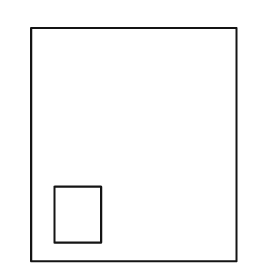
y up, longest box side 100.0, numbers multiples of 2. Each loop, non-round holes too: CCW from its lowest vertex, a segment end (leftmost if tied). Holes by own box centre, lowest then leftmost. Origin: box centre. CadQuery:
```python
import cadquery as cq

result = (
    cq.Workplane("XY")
    .moveTo(-44.0, -50.0)
    .lineTo(44.0, -50.0)
    .lineTo(44.0, 50.0)
    .lineTo(-44.0, 50.0)
    .close()
    .moveTo(-34.0, -42.0)
    .lineTo(-14.0, -42.0)
    .lineTo(-14.0, -18.0)
    .lineTo(-34.0, -18.0)
    .close()
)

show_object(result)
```